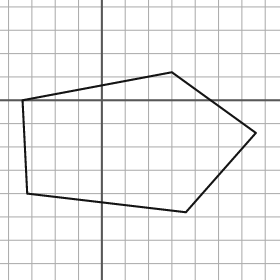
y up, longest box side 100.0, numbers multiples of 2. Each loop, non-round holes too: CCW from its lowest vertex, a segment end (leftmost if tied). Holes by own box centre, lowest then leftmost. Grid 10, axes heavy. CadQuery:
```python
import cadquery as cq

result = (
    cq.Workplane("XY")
    .moveTo(36.0, -48.0)
    .lineTo(66.0, -14.0)
    .lineTo(30.0, 12.0)
    .lineTo(-34.0, 0.0)
    .lineTo(-32.0, -40.0)
    .close()
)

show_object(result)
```